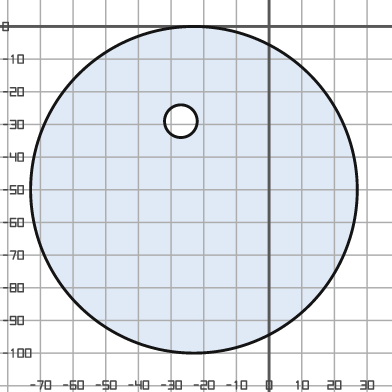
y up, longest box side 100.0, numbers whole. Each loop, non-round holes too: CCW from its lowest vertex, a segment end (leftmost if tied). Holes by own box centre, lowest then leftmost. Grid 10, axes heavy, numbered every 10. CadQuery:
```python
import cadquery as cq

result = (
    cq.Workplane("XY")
    .moveTo(-23.0, -50.0)
    .circle(50.0)
    .moveTo(-27.0, -29.0)
    .circle(5.0)
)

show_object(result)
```